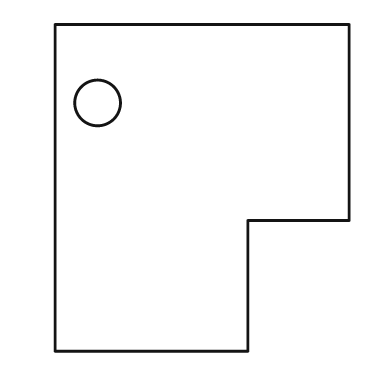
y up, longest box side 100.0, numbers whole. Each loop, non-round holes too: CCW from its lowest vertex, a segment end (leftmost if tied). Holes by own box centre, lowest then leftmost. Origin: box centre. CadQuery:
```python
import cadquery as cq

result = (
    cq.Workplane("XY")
    .moveTo(-45.0, -50.0)
    .lineTo(14.0, -50.0)
    .lineTo(14.0, -10.0)
    .lineTo(45.0, -10.0)
    .lineTo(45.0, 50.0)
    .lineTo(-45.0, 50.0)
    .close()
    .moveTo(-32.0, 26.0)
    .circle(7.0)
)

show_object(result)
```